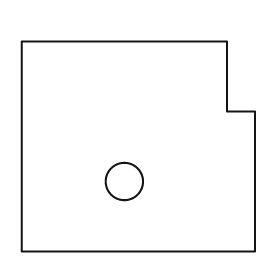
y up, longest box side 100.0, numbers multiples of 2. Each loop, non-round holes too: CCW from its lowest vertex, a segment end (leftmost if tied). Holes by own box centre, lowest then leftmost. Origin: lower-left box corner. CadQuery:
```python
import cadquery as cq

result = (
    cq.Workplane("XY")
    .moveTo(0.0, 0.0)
    .lineTo(100.0, 0.0)
    .lineTo(100.0, 60.0)
    .lineTo(88.0, 60.0)
    .lineTo(88.0, 90.0)
    .lineTo(0.0, 90.0)
    .close()
    .moveTo(44.0, 30.0)
    .circle(8.0)
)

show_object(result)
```